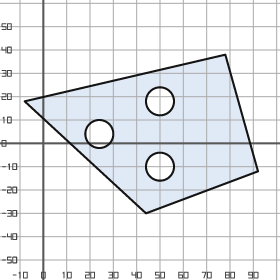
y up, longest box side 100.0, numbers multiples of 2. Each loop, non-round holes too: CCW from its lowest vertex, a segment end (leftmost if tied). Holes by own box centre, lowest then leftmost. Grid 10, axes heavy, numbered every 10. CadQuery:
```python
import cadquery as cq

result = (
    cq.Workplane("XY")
    .moveTo(44.0, -30.0)
    .lineTo(92.0, -12.0)
    .lineTo(78.0, 38.0)
    .lineTo(-8.0, 18.0)
    .close()
    .moveTo(50.0, -10.0)
    .circle(6.0)
    .moveTo(24.0, 4.0)
    .circle(6.0)
    .moveTo(50.0, 18.0)
    .circle(6.0)
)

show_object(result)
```